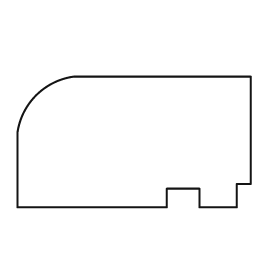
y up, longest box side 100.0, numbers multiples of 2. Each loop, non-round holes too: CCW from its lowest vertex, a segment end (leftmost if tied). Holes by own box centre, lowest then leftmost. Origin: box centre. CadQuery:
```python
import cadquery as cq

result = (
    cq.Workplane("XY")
    .moveTo(-50.0, -28.0)
    .lineTo(14.0, -28.0)
    .lineTo(14.0, -20.0)
    .lineTo(28.0, -20.0)
    .lineTo(28.0, -28.0)
    .lineTo(44.0, -28.0)
    .lineTo(44.0, -18.0)
    .lineTo(50.0, -18.0)
    .lineTo(50.0, 28.0)
    .lineTo(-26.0, 28.0)
    .threePointArc((-42.0, 20.0), (-50.0, 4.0))
    .close()
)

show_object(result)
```